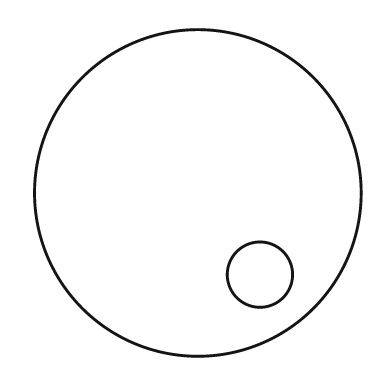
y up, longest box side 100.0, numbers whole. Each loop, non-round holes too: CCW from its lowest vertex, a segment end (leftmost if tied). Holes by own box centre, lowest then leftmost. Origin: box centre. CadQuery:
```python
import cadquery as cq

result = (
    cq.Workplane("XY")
    .moveTo(0.0, 0.0)
    .circle(50.0)
    .moveTo(19.0, -25.0)
    .circle(10.0)
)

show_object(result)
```